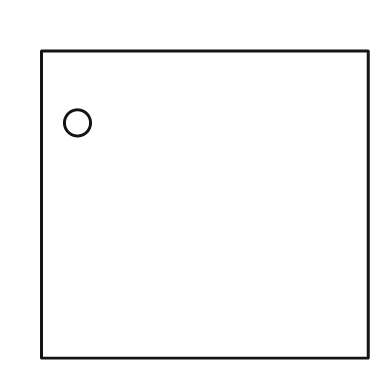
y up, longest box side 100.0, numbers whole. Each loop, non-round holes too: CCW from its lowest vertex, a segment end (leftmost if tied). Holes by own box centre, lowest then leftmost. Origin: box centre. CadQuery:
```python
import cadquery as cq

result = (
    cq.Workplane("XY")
    .moveTo(-50.0, -47.0)
    .lineTo(50.0, -47.0)
    .lineTo(50.0, 47.0)
    .lineTo(-50.0, 47.0)
    .close()
    .moveTo(-39.0, 25.0)
    .circle(4.0)
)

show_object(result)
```